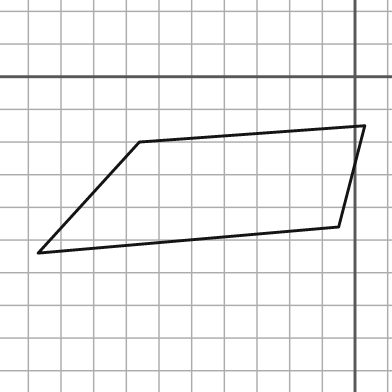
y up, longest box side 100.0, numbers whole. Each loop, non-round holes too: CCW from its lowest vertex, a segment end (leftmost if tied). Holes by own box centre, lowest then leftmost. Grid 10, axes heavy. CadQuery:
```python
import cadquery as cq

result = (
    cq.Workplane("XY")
    .moveTo(-97.0, -54.0)
    .lineTo(-5.0, -46.0)
    .lineTo(3.0, -15.0)
    .lineTo(-66.0, -20.0)
    .close()
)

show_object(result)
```